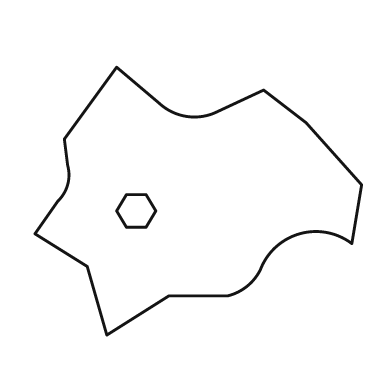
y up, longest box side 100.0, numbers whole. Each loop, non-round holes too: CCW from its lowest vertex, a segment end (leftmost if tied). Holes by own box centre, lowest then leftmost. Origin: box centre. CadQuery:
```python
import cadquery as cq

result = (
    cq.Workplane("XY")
    .moveTo(-28.0, -41.0)
    .lineTo(-9.0, -29.0)
    .lineTo(9.0, -29.0)
    .threePointArc((15.0, -26.0), (19.0, -21.0))
    .threePointArc((31.0, -10.0), (47.0, -13.0))
    .lineTo(50.0, 5.0)
    .lineTo(33.0, 24.0)
    .lineTo(20.0, 34.0)
    .lineTo(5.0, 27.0)
    .threePointArc((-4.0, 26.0), (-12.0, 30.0))
    .lineTo(-25.0, 41.0)
    .lineTo(-41.0, 19.0)
    .lineTo(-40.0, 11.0)
    .threePointArc((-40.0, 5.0), (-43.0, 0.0))
    .lineTo(-50.0, -10.0)
    .lineTo(-34.0, -20.0)
    .close()
    .moveTo(-22.0, -8.0)
    .lineTo(-16.0, -8.0)
    .lineTo(-13.0, -3.0)
    .lineTo(-16.0, 2.0)
    .lineTo(-22.0, 2.0)
    .lineTo(-25.0, -3.0)
    .close()
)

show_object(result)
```